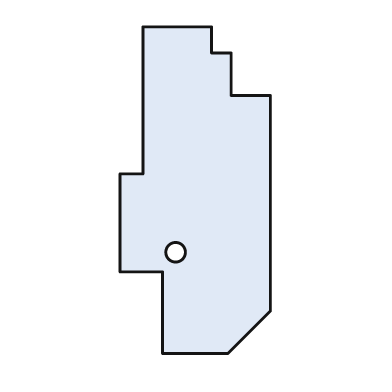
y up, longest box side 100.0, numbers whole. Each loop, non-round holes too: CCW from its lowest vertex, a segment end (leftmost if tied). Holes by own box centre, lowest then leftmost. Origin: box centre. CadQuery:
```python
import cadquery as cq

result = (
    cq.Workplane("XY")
    .moveTo(-10.0, -50.0)
    .lineTo(10.0, -50.0)
    .lineTo(23.0, -37.0)
    .lineTo(23.0, 29.0)
    .lineTo(11.0, 29.0)
    .lineTo(11.0, 42.0)
    .lineTo(5.0, 42.0)
    .lineTo(5.0, 50.0)
    .lineTo(-16.0, 50.0)
    .lineTo(-16.0, 5.0)
    .lineTo(-23.0, 5.0)
    .lineTo(-23.0, -25.0)
    .lineTo(-10.0, -25.0)
    .close()
    .moveTo(-6.0, -19.0)
    .circle(3.0)
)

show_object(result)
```